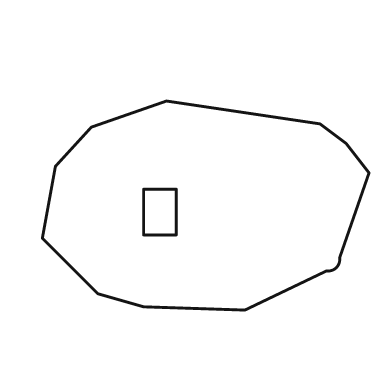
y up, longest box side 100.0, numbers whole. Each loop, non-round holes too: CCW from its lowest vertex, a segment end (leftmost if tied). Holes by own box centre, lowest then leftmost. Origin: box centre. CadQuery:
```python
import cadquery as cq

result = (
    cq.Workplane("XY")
    .moveTo(12.0, -32.0)
    .lineTo(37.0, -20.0)
    .threePointArc((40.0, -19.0), (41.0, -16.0))
    .lineTo(50.0, 10.0)
    .lineTo(43.0, 19.0)
    .lineTo(35.0, 25.0)
    .lineTo(-12.0, 32.0)
    .lineTo(-35.0, 24.0)
    .lineTo(-46.0, 12.0)
    .lineTo(-50.0, -10.0)
    .lineTo(-33.0, -27.0)
    .lineTo(-19.0, -31.0)
    .close()
    .moveTo(-19.0, -9.0)
    .lineTo(-9.0, -9.0)
    .lineTo(-9.0, 5.0)
    .lineTo(-19.0, 5.0)
    .close()
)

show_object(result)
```